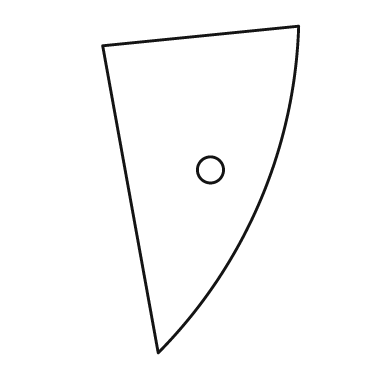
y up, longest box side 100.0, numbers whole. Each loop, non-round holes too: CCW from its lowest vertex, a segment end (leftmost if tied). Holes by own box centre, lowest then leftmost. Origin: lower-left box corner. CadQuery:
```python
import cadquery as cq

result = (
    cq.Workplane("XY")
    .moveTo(17.0, 0.0)
    .threePointArc((48.0, 46.0), (60.0, 100.0))
    .lineTo(0.0, 94.0)
    .close()
    .moveTo(33.0, 56.0)
    .circle(4.0)
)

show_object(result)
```